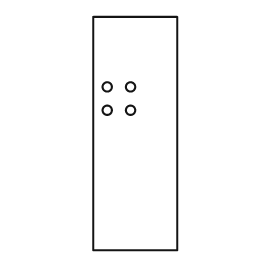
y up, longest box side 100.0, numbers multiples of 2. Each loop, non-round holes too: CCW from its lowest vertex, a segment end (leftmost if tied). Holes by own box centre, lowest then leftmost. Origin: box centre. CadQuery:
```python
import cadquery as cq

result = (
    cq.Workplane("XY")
    .moveTo(-18.0, -50.0)
    .lineTo(18.0, -50.0)
    .lineTo(18.0, 50.0)
    .lineTo(-18.0, 50.0)
    .close()
    .moveTo(-12.0, 10.0)
    .circle(2.0)
    .moveTo(-2.0, 10.0)
    .circle(2.0)
    .moveTo(-12.0, 20.0)
    .circle(2.0)
    .moveTo(-2.0, 20.0)
    .circle(2.0)
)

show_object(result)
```